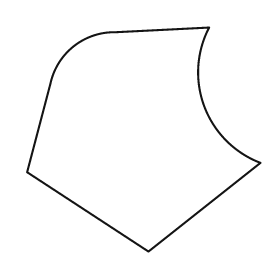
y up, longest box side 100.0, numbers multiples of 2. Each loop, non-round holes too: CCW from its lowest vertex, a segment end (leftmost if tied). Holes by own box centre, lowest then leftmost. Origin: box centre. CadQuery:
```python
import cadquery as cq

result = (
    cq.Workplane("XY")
    .moveTo(2.0, -48.0)
    .lineTo(50.0, -10.0)
    .threePointArc((26.0, 14.0), (28.0, 48.0))
    .lineTo(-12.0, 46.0)
    .threePointArc((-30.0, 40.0), (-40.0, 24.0))
    .lineTo(-50.0, -14.0)
    .close()
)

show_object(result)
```